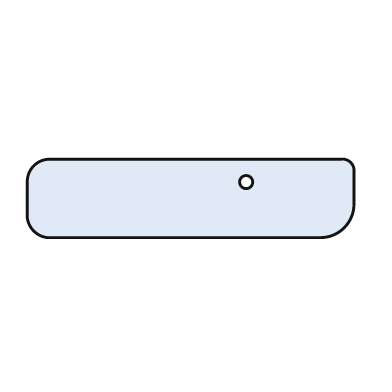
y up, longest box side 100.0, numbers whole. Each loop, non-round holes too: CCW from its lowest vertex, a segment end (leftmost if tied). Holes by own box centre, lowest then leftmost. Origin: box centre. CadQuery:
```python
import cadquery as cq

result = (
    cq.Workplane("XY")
    .moveTo(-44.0, -12.0)
    .lineTo(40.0, -12.0)
    .threePointArc((47.0, -9.0), (50.0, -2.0))
    .lineTo(50.0, 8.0)
    .threePointArc((49.0, 11.0), (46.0, 12.0))
    .lineTo(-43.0, 12.0)
    .threePointArc((-48.0, 10.0), (-50.0, 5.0))
    .lineTo(-50.0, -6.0)
    .threePointArc((-48.0, -10.0), (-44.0, -12.0))
    .close()
    .moveTo(17.0, 5.0)
    .circle(2.0)
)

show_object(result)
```